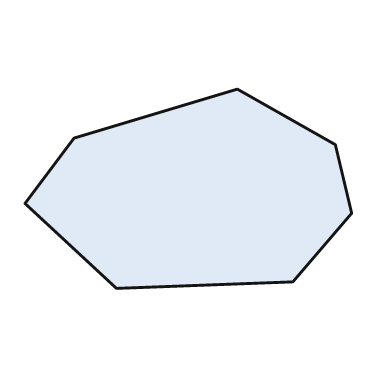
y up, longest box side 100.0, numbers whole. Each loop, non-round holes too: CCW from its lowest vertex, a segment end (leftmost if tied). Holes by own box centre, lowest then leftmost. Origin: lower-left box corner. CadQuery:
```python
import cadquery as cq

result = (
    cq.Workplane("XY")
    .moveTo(28.0, 0.0)
    .lineTo(82.0, 2.0)
    .lineTo(100.0, 23.0)
    .lineTo(95.0, 44.0)
    .lineTo(65.0, 61.0)
    .lineTo(15.0, 46.0)
    .lineTo(0.0, 26.0)
    .close()
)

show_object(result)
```